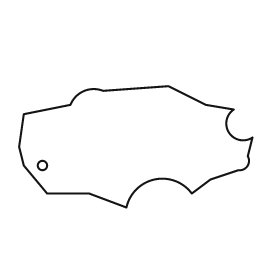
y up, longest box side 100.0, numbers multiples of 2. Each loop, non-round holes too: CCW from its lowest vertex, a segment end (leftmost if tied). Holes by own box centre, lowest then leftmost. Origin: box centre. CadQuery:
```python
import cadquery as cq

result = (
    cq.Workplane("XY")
    .moveTo(-4.0, -26.0)
    .threePointArc((8.0, -14.0), (24.0, -20.0))
    .lineTo(32.0, -14.0)
    .lineTo(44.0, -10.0)
    .threePointArc((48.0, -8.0), (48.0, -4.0))
    .lineTo(50.0, 4.0)
    .threePointArc((40.0, 6.0), (42.0, 16.0))
    .lineTo(30.0, 18.0)
    .lineTo(14.0, 26.0)
    .lineTo(-14.0, 24.0)
    .threePointArc((-22.0, 24.0), (-28.0, 18.0))
    .lineTo(-48.0, 14.0)
    .lineTo(-50.0, 0.0)
    .lineTo(-48.0, -8.0)
    .lineTo(-38.0, -20.0)
    .lineTo(-20.0, -20.0)
    .close()
    .moveTo(-40.0, -8.0)
    .circle(2.0)
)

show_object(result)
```